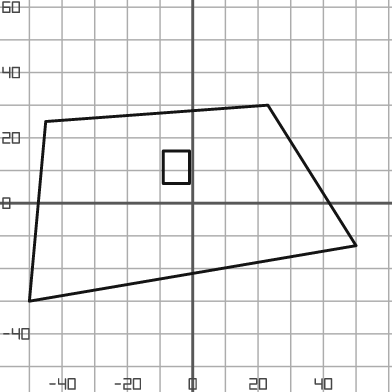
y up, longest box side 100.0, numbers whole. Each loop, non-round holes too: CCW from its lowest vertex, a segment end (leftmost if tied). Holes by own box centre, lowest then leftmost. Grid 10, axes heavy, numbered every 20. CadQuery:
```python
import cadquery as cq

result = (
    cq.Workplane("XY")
    .moveTo(-50.0, -30.0)
    .lineTo(50.0, -13.0)
    .lineTo(23.0, 30.0)
    .lineTo(-45.0, 25.0)
    .close()
    .moveTo(-9.0, 6.0)
    .lineTo(-1.0, 6.0)
    .lineTo(-1.0, 16.0)
    .lineTo(-9.0, 16.0)
    .close()
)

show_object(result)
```